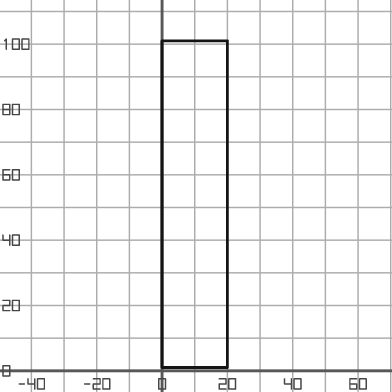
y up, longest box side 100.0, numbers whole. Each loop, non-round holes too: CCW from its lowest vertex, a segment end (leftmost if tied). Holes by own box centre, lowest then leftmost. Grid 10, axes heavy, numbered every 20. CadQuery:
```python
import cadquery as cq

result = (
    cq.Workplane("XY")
    .moveTo(0.0, 1.0)
    .lineTo(20.0, 1.0)
    .lineTo(20.0, 101.0)
    .lineTo(0.0, 101.0)
    .close()
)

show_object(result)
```